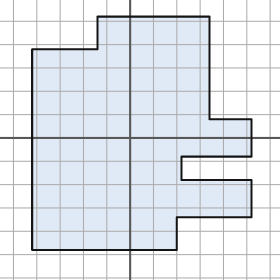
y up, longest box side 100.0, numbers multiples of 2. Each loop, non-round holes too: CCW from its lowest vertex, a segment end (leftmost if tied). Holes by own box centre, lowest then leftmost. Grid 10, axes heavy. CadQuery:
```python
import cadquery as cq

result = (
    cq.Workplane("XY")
    .moveTo(-42.0, -48.0)
    .lineTo(20.0, -48.0)
    .lineTo(20.0, -34.0)
    .lineTo(52.0, -34.0)
    .lineTo(52.0, -18.0)
    .lineTo(22.0, -18.0)
    .lineTo(22.0, -8.0)
    .lineTo(52.0, -8.0)
    .lineTo(52.0, 8.0)
    .lineTo(34.0, 8.0)
    .lineTo(34.0, 52.0)
    .lineTo(-14.0, 52.0)
    .lineTo(-14.0, 38.0)
    .lineTo(-42.0, 38.0)
    .close()
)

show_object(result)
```